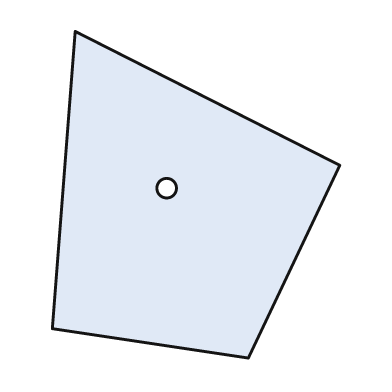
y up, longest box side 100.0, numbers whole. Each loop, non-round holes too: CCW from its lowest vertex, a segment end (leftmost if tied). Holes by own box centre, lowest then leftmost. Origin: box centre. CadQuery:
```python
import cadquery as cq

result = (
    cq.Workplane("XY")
    .moveTo(16.0, -50.0)
    .lineTo(44.0, 9.0)
    .lineTo(-37.0, 50.0)
    .lineTo(-44.0, -41.0)
    .close()
    .moveTo(-9.0, 2.0)
    .circle(3.0)
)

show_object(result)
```